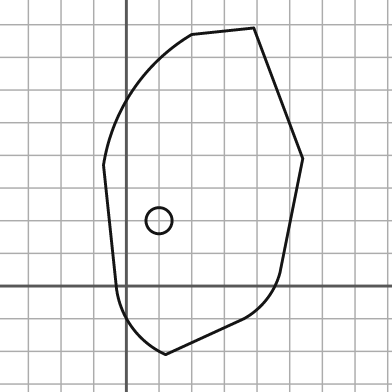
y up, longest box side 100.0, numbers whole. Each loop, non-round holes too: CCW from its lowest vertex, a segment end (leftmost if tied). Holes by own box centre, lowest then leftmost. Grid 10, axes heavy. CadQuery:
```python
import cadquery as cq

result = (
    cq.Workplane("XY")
    .moveTo(12.0, -21.0)
    .lineTo(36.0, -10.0)
    .threePointArc((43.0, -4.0), (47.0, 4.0))
    .lineTo(54.0, 39.0)
    .lineTo(39.0, 79.0)
    .lineTo(20.0, 77.0)
    .threePointArc((2.0, 60.0), (-7.0, 37.0))
    .lineTo(-3.0, -1.0)
    .threePointArc((2.0, -13.0), (12.0, -21.0))
    .close()
    .moveTo(10.0, 20.0)
    .circle(4.0)
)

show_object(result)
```